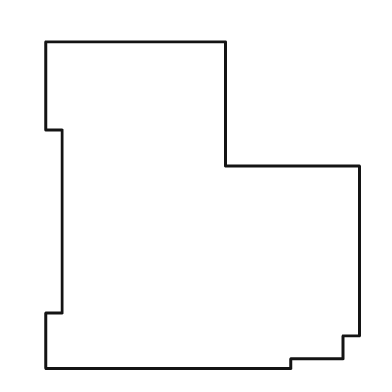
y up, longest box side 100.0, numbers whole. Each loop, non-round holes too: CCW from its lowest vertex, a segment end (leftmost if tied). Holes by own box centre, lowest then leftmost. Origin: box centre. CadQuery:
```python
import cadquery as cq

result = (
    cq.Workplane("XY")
    .moveTo(-48.0, -50.0)
    .lineTo(27.0, -50.0)
    .lineTo(27.0, -47.0)
    .lineTo(43.0, -47.0)
    .lineTo(43.0, -40.0)
    .lineTo(48.0, -40.0)
    .lineTo(48.0, 12.0)
    .lineTo(7.0, 12.0)
    .lineTo(7.0, 50.0)
    .lineTo(-48.0, 50.0)
    .lineTo(-48.0, 23.0)
    .lineTo(-43.0, 23.0)
    .lineTo(-43.0, -33.0)
    .lineTo(-48.0, -33.0)
    .close()
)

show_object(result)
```